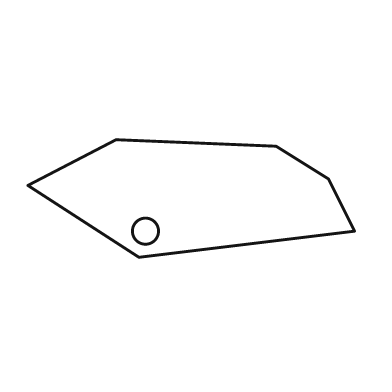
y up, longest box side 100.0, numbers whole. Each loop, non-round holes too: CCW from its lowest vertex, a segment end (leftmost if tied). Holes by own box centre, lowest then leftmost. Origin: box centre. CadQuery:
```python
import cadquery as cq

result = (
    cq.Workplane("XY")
    .moveTo(-16.0, -18.0)
    .lineTo(50.0, -10.0)
    .lineTo(42.0, 6.0)
    .lineTo(26.0, 16.0)
    .lineTo(-23.0, 18.0)
    .lineTo(-50.0, 4.0)
    .close()
    .moveTo(-14.0, -10.0)
    .circle(4.0)
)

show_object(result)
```